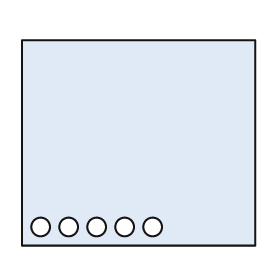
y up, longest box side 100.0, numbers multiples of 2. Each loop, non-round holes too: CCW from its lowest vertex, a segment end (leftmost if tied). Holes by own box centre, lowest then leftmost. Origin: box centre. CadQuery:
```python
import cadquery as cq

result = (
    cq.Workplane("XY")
    .moveTo(-50.0, -44.0)
    .lineTo(50.0, -44.0)
    .lineTo(50.0, 44.0)
    .lineTo(-50.0, 44.0)
    .close()
    .moveTo(-42.0, -36.0)
    .circle(4.0)
    .moveTo(-30.0, -36.0)
    .circle(4.0)
    .moveTo(-18.0, -36.0)
    .circle(4.0)
    .moveTo(-6.0, -36.0)
    .circle(4.0)
    .moveTo(6.0, -36.0)
    .circle(4.0)
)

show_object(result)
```